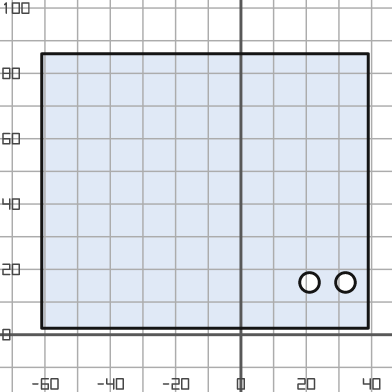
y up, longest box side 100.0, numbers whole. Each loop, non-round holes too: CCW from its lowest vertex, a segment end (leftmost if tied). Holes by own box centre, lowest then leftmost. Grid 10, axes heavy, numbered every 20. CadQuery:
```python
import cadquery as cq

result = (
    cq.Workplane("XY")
    .moveTo(-61.0, 2.0)
    .lineTo(39.0, 2.0)
    .lineTo(39.0, 86.0)
    .lineTo(-61.0, 86.0)
    .close()
    .moveTo(21.0, 16.0)
    .circle(3.0)
    .moveTo(32.0, 16.0)
    .circle(3.0)
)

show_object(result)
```